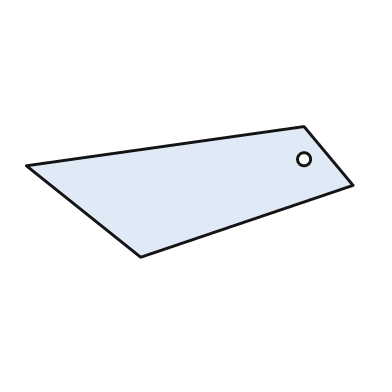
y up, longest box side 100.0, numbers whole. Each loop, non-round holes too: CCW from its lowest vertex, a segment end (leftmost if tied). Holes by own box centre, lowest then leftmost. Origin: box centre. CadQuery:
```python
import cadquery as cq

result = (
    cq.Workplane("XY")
    .moveTo(-15.0, -20.0)
    .lineTo(50.0, 2.0)
    .lineTo(35.0, 20.0)
    .lineTo(-50.0, 8.0)
    .close()
    .moveTo(35.0, 10.0)
    .circle(2.0)
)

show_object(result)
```